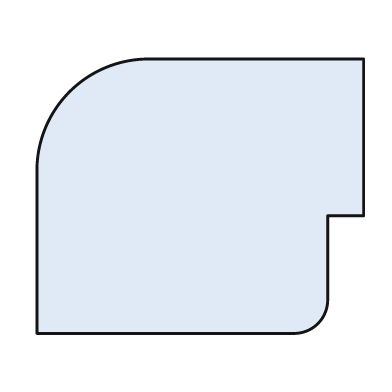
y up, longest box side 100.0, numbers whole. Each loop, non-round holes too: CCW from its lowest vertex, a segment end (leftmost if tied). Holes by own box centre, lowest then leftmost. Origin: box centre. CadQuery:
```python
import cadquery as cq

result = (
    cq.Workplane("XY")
    .moveTo(-50.0, -42.0)
    .lineTo(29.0, -42.0)
    .threePointArc((36.0, -39.0), (39.0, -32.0))
    .lineTo(39.0, -6.0)
    .lineTo(50.0, -6.0)
    .lineTo(50.0, 42.0)
    .lineTo(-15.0, 42.0)
    .threePointArc((-40.0, 32.0), (-50.0, 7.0))
    .close()
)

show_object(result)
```